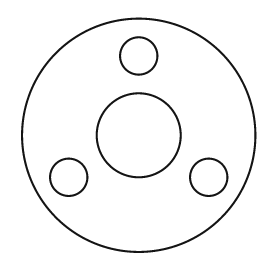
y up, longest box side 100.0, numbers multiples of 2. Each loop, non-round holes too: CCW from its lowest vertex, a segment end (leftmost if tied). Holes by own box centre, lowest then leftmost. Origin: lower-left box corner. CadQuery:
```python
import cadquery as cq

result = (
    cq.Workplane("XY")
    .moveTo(50.0, 50.0)
    .circle(50.0)
    .moveTo(20.0, 32.0)
    .circle(8.0)
    .moveTo(80.0, 32.0)
    .circle(8.0)
    .moveTo(50.0, 50.0)
    .circle(18.0)
    .moveTo(50.0, 84.0)
    .circle(8.0)
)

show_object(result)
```